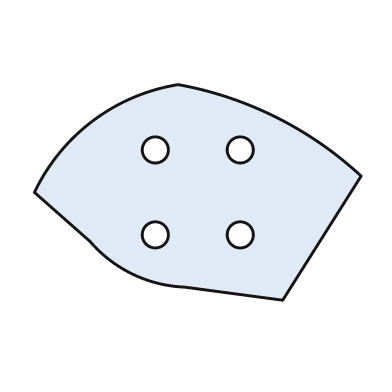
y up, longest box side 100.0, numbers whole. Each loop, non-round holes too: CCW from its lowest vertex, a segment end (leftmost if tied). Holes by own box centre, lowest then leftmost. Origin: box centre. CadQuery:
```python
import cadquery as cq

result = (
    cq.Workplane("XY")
    .moveTo(26.0, -33.0)
    .lineTo(50.0, 5.0)
    .threePointArc((24.0, 23.0), (-6.0, 33.0))
    .threePointArc((-32.0, 22.0), (-50.0, 0.0))
    .lineTo(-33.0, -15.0)
    .threePointArc((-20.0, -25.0), (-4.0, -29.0))
    .close()
    .moveTo(-13.0, -13.0)
    .circle(4.0)
    .moveTo(13.0, -13.0)
    .circle(4.0)
    .moveTo(-13.0, 13.0)
    .circle(4.0)
    .moveTo(13.0, 13.0)
    .circle(4.0)
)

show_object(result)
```